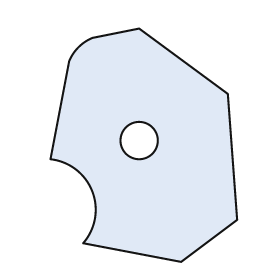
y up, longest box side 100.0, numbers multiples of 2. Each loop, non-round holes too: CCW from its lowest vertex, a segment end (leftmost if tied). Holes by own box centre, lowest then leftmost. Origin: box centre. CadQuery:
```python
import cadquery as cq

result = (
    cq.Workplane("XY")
    .moveTo(16.0, -50.0)
    .lineTo(40.0, -32.0)
    .lineTo(36.0, 22.0)
    .lineTo(-2.0, 50.0)
    .lineTo(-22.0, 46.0)
    .threePointArc((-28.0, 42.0), (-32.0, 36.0))
    .lineTo(-40.0, -6.0)
    .threePointArc((-22.0, -20.0), (-26.0, -42.0))
    .close()
    .moveTo(-2.0, 2.0)
    .circle(8.0)
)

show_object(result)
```